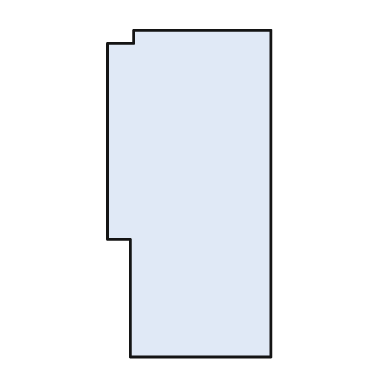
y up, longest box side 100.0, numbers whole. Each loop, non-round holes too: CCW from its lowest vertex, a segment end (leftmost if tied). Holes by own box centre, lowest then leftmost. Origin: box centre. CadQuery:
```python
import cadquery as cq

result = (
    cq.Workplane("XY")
    .moveTo(-18.0, -50.0)
    .lineTo(25.0, -50.0)
    .lineTo(25.0, 50.0)
    .lineTo(-17.0, 50.0)
    .lineTo(-17.0, 46.0)
    .lineTo(-25.0, 46.0)
    .lineTo(-25.0, -14.0)
    .lineTo(-18.0, -14.0)
    .close()
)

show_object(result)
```